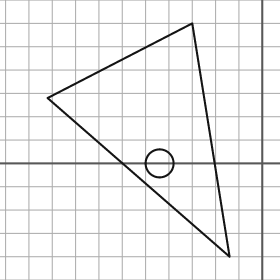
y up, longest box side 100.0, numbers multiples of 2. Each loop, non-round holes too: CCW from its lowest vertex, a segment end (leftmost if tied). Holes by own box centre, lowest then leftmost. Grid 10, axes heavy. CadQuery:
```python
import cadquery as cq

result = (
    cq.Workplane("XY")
    .moveTo(-14.0, -40.0)
    .lineTo(-30.0, 60.0)
    .lineTo(-92.0, 28.0)
    .close()
    .moveTo(-44.0, 0.0)
    .circle(6.0)
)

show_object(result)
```